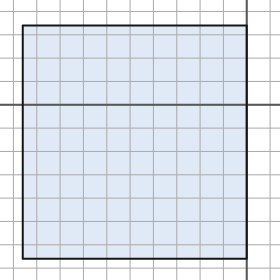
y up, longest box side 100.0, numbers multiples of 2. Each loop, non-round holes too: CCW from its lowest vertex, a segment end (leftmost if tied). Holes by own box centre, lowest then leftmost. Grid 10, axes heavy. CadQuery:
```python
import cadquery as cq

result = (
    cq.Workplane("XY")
    .moveTo(-96.0, -66.0)
    .lineTo(0.0, -66.0)
    .lineTo(0.0, 34.0)
    .lineTo(-96.0, 34.0)
    .close()
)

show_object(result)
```